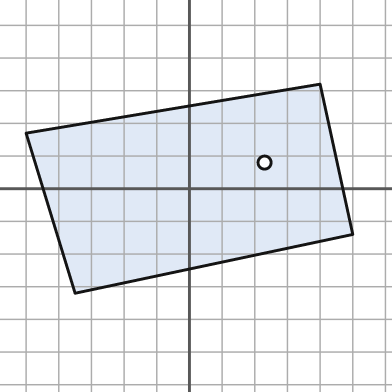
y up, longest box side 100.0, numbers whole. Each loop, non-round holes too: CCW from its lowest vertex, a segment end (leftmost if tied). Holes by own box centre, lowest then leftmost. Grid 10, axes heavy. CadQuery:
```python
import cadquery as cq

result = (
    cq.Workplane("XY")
    .moveTo(-35.0, -32.0)
    .lineTo(50.0, -14.0)
    .lineTo(40.0, 32.0)
    .lineTo(-50.0, 17.0)
    .close()
    .moveTo(23.0, 8.0)
    .circle(2.0)
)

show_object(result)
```